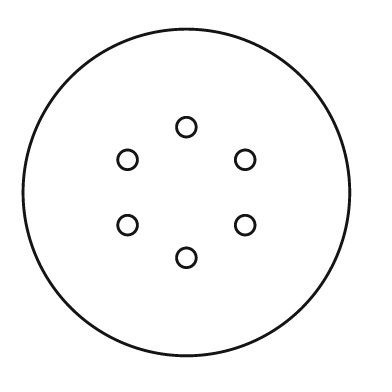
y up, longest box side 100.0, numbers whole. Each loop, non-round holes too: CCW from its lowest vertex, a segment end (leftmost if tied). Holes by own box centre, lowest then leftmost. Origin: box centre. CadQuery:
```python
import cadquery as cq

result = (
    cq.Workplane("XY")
    .moveTo(0.0, 0.0)
    .circle(50.0)
    .moveTo(0.0, -20.0)
    .circle(3.0)
    .moveTo(-18.0, -10.0)
    .circle(3.0)
    .moveTo(18.0, -10.0)
    .circle(3.0)
    .moveTo(-18.0, 10.0)
    .circle(3.0)
    .moveTo(18.0, 10.0)
    .circle(3.0)
    .moveTo(0.0, 20.0)
    .circle(3.0)
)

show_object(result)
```